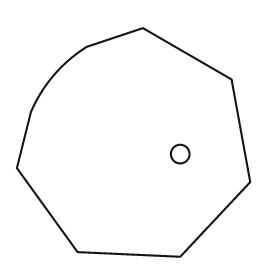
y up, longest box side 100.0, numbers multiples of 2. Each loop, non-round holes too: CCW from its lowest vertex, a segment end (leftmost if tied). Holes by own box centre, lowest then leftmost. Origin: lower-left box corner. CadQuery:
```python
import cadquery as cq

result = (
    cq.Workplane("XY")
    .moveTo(70.0, 0.0)
    .lineTo(100.0, 32.0)
    .lineTo(92.0, 76.0)
    .lineTo(54.0, 98.0)
    .lineTo(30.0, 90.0)
    .threePointArc((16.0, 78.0), (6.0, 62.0))
    .lineTo(0.0, 38.0)
    .lineTo(26.0, 2.0)
    .close()
    .moveTo(70.0, 44.0)
    .circle(4.0)
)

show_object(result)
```